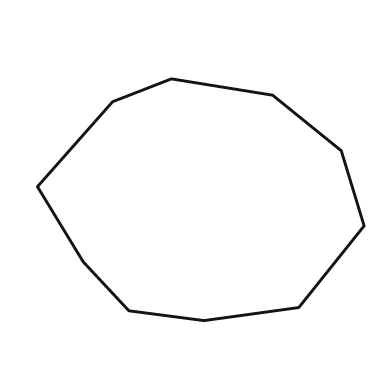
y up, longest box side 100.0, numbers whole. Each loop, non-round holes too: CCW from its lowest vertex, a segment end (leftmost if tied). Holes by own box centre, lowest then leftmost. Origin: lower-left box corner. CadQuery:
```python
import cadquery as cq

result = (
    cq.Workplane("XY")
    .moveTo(51.0, 0.0)
    .lineTo(80.0, 4.0)
    .lineTo(100.0, 29.0)
    .lineTo(93.0, 52.0)
    .lineTo(72.0, 69.0)
    .lineTo(41.0, 74.0)
    .lineTo(23.0, 67.0)
    .lineTo(0.0, 41.0)
    .lineTo(14.0, 18.0)
    .lineTo(28.0, 3.0)
    .close()
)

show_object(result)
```